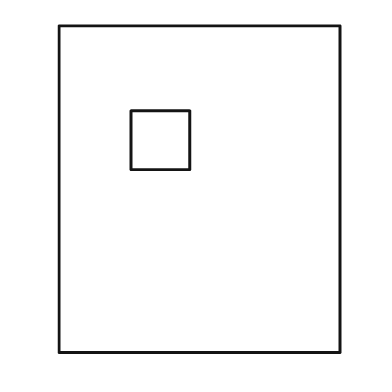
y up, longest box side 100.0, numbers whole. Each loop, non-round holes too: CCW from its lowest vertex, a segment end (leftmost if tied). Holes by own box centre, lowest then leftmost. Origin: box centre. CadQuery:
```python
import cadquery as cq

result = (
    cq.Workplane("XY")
    .moveTo(-43.0, -50.0)
    .lineTo(43.0, -50.0)
    .lineTo(43.0, 50.0)
    .lineTo(-43.0, 50.0)
    .close()
    .moveTo(-21.0, 6.0)
    .lineTo(-3.0, 6.0)
    .lineTo(-3.0, 24.0)
    .lineTo(-21.0, 24.0)
    .close()
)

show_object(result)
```